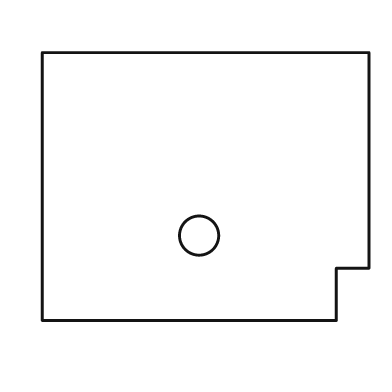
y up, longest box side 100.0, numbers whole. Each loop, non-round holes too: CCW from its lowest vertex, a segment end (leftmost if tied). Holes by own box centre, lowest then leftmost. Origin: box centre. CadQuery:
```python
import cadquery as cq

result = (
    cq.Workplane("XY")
    .moveTo(-50.0, -41.0)
    .lineTo(40.0, -41.0)
    .lineTo(40.0, -25.0)
    .lineTo(50.0, -25.0)
    .lineTo(50.0, 41.0)
    .lineTo(-50.0, 41.0)
    .close()
    .moveTo(-2.0, -15.0)
    .circle(6.0)
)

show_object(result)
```